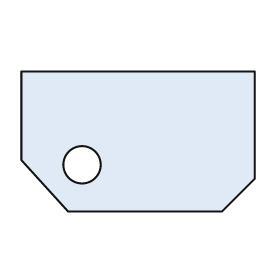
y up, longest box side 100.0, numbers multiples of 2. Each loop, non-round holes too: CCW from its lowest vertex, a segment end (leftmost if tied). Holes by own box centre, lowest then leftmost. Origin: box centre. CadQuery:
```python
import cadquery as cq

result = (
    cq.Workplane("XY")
    .moveTo(-30.0, -30.0)
    .lineTo(36.0, -30.0)
    .lineTo(50.0, -16.0)
    .lineTo(50.0, 30.0)
    .lineTo(-50.0, 30.0)
    .lineTo(-50.0, -8.0)
    .close()
    .moveTo(-24.0, -10.0)
    .circle(8.0)
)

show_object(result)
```